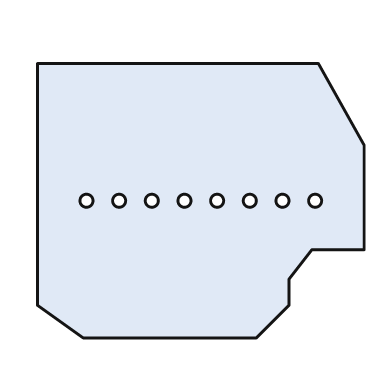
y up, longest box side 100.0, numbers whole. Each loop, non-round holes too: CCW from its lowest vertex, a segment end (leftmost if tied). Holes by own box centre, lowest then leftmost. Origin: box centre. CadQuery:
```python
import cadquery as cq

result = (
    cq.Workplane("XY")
    .moveTo(-36.0, -42.0)
    .lineTo(17.0, -42.0)
    .lineTo(27.0, -32.0)
    .lineTo(27.0, -24.0)
    .lineTo(34.0, -15.0)
    .lineTo(50.0, -15.0)
    .lineTo(50.0, 17.0)
    .lineTo(36.0, 42.0)
    .lineTo(-50.0, 42.0)
    .lineTo(-50.0, -32.0)
    .close()
    .moveTo(-35.0, 0.0)
    .circle(2.0)
    .moveTo(-25.0, 0.0)
    .circle(2.0)
    .moveTo(-15.0, 0.0)
    .circle(2.0)
    .moveTo(-5.0, 0.0)
    .circle(2.0)
    .moveTo(5.0, 0.0)
    .circle(2.0)
    .moveTo(15.0, 0.0)
    .circle(2.0)
    .moveTo(25.0, 0.0)
    .circle(2.0)
    .moveTo(35.0, 0.0)
    .circle(2.0)
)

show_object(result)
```